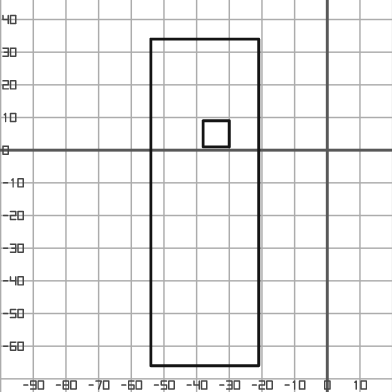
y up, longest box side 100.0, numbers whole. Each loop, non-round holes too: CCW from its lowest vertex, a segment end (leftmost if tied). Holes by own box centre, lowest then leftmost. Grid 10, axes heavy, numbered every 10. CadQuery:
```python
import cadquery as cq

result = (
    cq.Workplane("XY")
    .moveTo(-54.0, -66.0)
    .lineTo(-21.0, -66.0)
    .lineTo(-21.0, 34.0)
    .lineTo(-54.0, 34.0)
    .close()
    .moveTo(-38.0, 1.0)
    .lineTo(-30.0, 1.0)
    .lineTo(-30.0, 9.0)
    .lineTo(-38.0, 9.0)
    .close()
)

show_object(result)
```